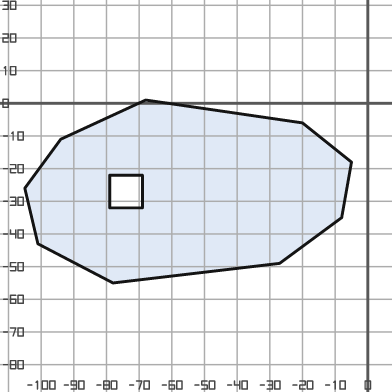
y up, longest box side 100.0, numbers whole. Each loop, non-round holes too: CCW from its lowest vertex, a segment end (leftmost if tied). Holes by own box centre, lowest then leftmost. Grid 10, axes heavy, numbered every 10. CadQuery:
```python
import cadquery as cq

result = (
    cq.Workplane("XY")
    .moveTo(-78.0, -55.0)
    .lineTo(-27.0, -49.0)
    .lineTo(-8.0, -35.0)
    .lineTo(-5.0, -18.0)
    .lineTo(-20.0, -6.0)
    .lineTo(-68.0, 1.0)
    .lineTo(-94.0, -11.0)
    .lineTo(-105.0, -26.0)
    .lineTo(-101.0, -43.0)
    .close()
    .moveTo(-79.0, -32.0)
    .lineTo(-69.0, -32.0)
    .lineTo(-69.0, -22.0)
    .lineTo(-79.0, -22.0)
    .close()
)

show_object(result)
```